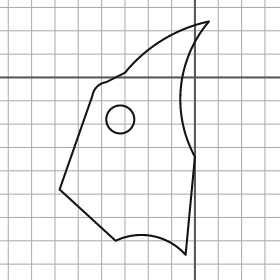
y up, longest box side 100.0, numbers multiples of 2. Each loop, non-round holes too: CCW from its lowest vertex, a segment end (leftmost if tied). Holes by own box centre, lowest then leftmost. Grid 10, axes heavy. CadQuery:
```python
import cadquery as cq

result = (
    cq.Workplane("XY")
    .moveTo(-4.0, -76.0)
    .lineTo(0.0, -34.0)
    .threePointArc((-6.0, -4.0), (6.0, 24.0))
    .threePointArc((-14.0, 16.0), (-30.0, 2.0))
    .lineTo(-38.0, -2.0)
    .threePointArc((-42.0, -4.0), (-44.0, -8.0))
    .lineTo(-58.0, -48.0)
    .lineTo(-34.0, -70.0)
    .threePointArc((-18.0, -68.0), (-4.0, -76.0))
    .close()
    .moveTo(-32.0, -18.0)
    .circle(6.0)
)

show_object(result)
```